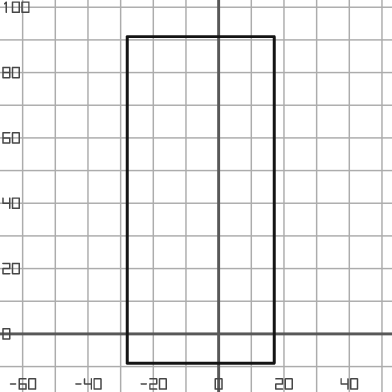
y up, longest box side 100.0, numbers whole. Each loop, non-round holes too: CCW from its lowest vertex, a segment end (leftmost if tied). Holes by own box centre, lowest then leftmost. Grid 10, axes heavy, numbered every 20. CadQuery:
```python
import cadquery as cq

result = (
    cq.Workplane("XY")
    .moveTo(-28.0, -9.0)
    .lineTo(17.0, -9.0)
    .lineTo(17.0, 91.0)
    .lineTo(-28.0, 91.0)
    .close()
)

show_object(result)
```